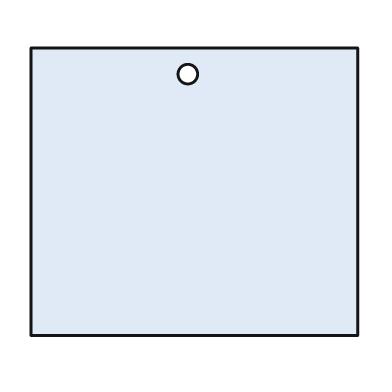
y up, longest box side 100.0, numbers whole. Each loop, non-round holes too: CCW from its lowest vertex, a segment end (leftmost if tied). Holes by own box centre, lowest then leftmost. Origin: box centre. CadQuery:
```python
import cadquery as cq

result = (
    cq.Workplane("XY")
    .moveTo(-50.0, -44.0)
    .lineTo(50.0, -44.0)
    .lineTo(50.0, 44.0)
    .lineTo(-50.0, 44.0)
    .close()
    .moveTo(-2.0, 36.0)
    .circle(3.0)
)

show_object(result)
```